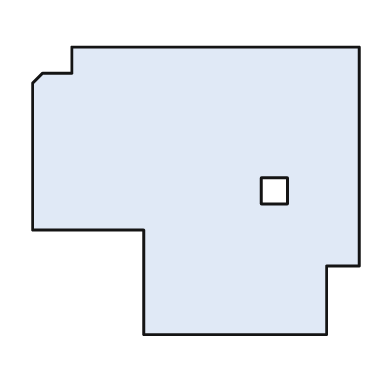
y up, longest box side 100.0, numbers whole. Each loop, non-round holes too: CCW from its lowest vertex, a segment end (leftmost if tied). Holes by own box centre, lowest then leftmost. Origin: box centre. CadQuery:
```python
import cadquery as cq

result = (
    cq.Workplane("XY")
    .moveTo(-16.0, -44.0)
    .lineTo(40.0, -44.0)
    .lineTo(40.0, -23.0)
    .lineTo(50.0, -23.0)
    .lineTo(50.0, 44.0)
    .lineTo(-38.0, 44.0)
    .lineTo(-38.0, 36.0)
    .lineTo(-47.0, 36.0)
    .lineTo(-50.0, 33.0)
    .lineTo(-50.0, -12.0)
    .lineTo(-16.0, -12.0)
    .close()
    .moveTo(20.0, -4.0)
    .lineTo(28.0, -4.0)
    .lineTo(28.0, 4.0)
    .lineTo(20.0, 4.0)
    .close()
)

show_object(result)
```